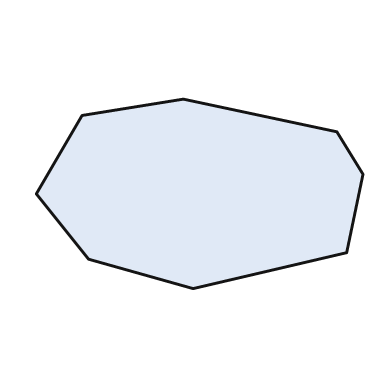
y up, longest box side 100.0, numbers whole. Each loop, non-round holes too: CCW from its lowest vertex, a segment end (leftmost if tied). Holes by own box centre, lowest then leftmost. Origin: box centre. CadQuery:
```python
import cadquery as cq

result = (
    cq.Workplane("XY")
    .moveTo(-2.0, -29.0)
    .lineTo(45.0, -18.0)
    .lineTo(50.0, 6.0)
    .lineTo(42.0, 19.0)
    .lineTo(-5.0, 29.0)
    .lineTo(-36.0, 24.0)
    .lineTo(-50.0, 0.0)
    .lineTo(-34.0, -20.0)
    .close()
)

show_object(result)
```